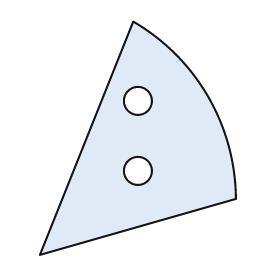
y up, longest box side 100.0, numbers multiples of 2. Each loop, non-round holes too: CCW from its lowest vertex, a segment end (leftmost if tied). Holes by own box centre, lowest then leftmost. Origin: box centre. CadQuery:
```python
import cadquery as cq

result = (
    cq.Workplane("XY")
    .moveTo(-42.0, -50.0)
    .lineTo(42.0, -26.0)
    .threePointArc((30.0, 18.0), (-2.0, 50.0))
    .close()
    .moveTo(0.0, -14.0)
    .circle(6.0)
    .moveTo(0.0, 16.0)
    .circle(6.0)
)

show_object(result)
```